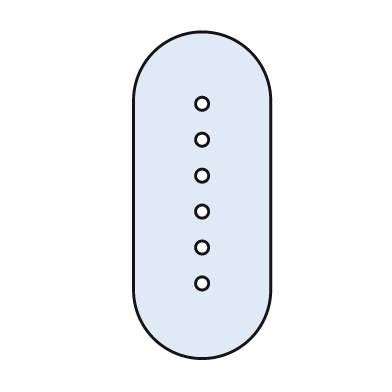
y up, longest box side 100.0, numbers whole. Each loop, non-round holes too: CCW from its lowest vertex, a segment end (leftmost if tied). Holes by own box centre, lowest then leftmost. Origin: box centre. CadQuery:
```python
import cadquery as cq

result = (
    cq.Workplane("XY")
    .moveTo(-21.0, -29.0)
    .threePointArc((0.0, -50.0), (21.0, -29.0))
    .lineTo(21.0, 29.0)
    .threePointArc((0.0, 50.0), (-21.0, 29.0))
    .close()
    .moveTo(0.0, -27.0)
    .circle(2.0)
    .moveTo(0.0, -16.0)
    .circle(2.0)
    .moveTo(0.0, -5.0)
    .circle(2.0)
    .moveTo(0.0, 6.0)
    .circle(2.0)
    .moveTo(0.0, 17.0)
    .circle(2.0)
    .moveTo(0.0, 28.0)
    .circle(2.0)
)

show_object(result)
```